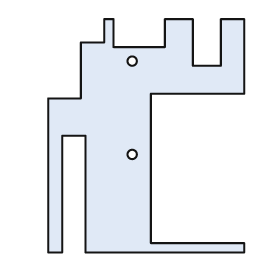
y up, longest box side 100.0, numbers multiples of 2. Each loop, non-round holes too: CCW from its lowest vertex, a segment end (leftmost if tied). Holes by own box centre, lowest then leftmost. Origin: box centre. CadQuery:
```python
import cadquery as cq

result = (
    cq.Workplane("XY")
    .moveTo(-42.0, -50.0)
    .lineTo(-36.0, -50.0)
    .lineTo(-36.0, 0.0)
    .lineTo(-26.0, 0.0)
    .lineTo(-26.0, -50.0)
    .lineTo(42.0, -50.0)
    .lineTo(42.0, -46.0)
    .lineTo(2.0, -46.0)
    .lineTo(2.0, 18.0)
    .lineTo(42.0, 18.0)
    .lineTo(42.0, 50.0)
    .lineTo(32.0, 50.0)
    .lineTo(32.0, 30.0)
    .lineTo(20.0, 30.0)
    .lineTo(20.0, 50.0)
    .lineTo(8.0, 50.0)
    .lineTo(8.0, 38.0)
    .lineTo(-14.0, 38.0)
    .lineTo(-14.0, 50.0)
    .lineTo(-18.0, 50.0)
    .lineTo(-18.0, 40.0)
    .lineTo(-28.0, 40.0)
    .lineTo(-28.0, 16.0)
    .lineTo(-42.0, 16.0)
    .close()
    .moveTo(-6.0, -8.0)
    .circle(2.0)
    .moveTo(-6.0, 32.0)
    .circle(2.0)
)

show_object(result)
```